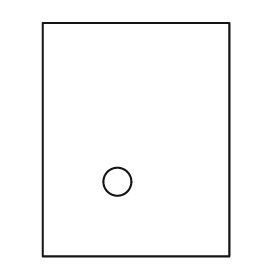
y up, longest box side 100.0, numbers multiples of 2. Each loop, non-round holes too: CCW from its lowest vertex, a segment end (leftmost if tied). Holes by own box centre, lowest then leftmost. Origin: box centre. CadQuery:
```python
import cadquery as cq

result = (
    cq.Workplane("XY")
    .moveTo(-40.0, -50.0)
    .lineTo(40.0, -50.0)
    .lineTo(40.0, 50.0)
    .lineTo(-40.0, 50.0)
    .close()
    .moveTo(-8.0, -18.0)
    .circle(6.0)
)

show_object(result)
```